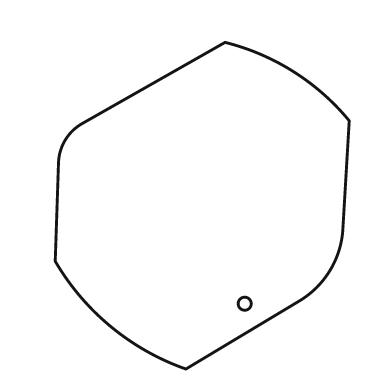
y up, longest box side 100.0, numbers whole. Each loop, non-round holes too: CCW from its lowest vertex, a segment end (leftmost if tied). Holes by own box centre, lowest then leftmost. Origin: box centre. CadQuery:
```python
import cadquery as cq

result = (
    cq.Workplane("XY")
    .moveTo(-5.0, -50.0)
    .lineTo(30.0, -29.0)
    .threePointArc((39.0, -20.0), (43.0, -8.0))
    .lineTo(45.0, 26.0)
    .threePointArc((28.0, 41.0), (7.0, 50.0))
    .lineTo(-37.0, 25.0)
    .threePointArc((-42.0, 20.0), (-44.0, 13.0))
    .lineTo(-45.0, -17.0)
    .threePointArc((-28.0, -37.0), (-5.0, -50.0))
    .close()
    .moveTo(13.0, -30.0)
    .circle(2.0)
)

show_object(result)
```